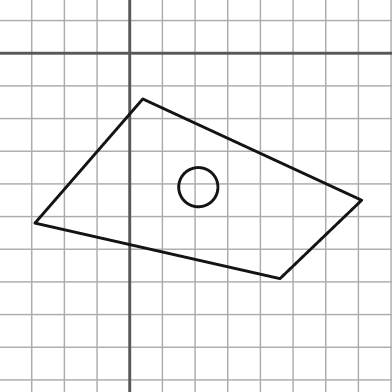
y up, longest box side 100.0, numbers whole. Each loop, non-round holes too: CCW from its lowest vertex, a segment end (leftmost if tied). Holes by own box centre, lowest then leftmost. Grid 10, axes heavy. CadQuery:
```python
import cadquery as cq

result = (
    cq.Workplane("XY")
    .moveTo(46.0, -69.0)
    .lineTo(71.0, -45.0)
    .lineTo(4.0, -14.0)
    .lineTo(-29.0, -52.0)
    .close()
    .moveTo(21.0, -41.0)
    .circle(6.0)
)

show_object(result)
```